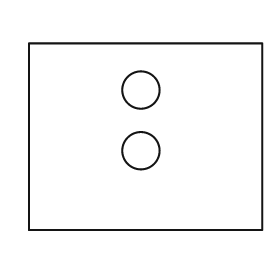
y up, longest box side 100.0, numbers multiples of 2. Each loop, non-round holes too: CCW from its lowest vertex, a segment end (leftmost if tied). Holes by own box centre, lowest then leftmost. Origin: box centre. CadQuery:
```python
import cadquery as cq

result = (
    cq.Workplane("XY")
    .moveTo(-50.0, -40.0)
    .lineTo(50.0, -40.0)
    .lineTo(50.0, 40.0)
    .lineTo(-50.0, 40.0)
    .close()
    .moveTo(-2.0, -6.0)
    .circle(8.0)
    .moveTo(-2.0, 20.0)
    .circle(8.0)
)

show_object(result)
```